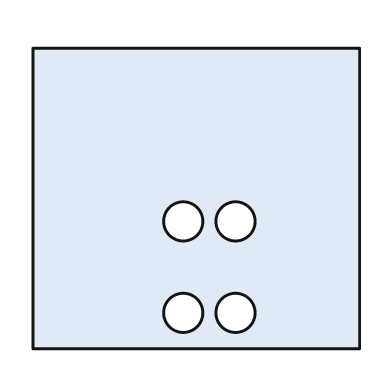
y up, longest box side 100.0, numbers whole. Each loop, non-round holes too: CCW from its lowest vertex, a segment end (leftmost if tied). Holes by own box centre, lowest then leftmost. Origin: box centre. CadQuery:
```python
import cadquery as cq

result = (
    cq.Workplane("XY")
    .moveTo(-50.0, -46.0)
    .lineTo(50.0, -46.0)
    .lineTo(50.0, 46.0)
    .lineTo(-50.0, 46.0)
    .close()
    .moveTo(-4.0, -35.0)
    .circle(6.0)
    .moveTo(12.0, -35.0)
    .circle(6.0)
    .moveTo(-4.0, -7.0)
    .circle(6.0)
    .moveTo(12.0, -7.0)
    .circle(6.0)
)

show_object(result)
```